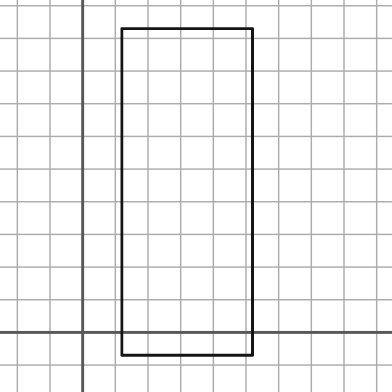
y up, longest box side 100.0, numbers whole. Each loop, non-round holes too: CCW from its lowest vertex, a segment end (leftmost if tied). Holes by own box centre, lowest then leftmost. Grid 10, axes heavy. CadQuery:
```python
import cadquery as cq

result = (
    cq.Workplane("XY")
    .moveTo(12.0, -7.0)
    .lineTo(52.0, -7.0)
    .lineTo(52.0, 93.0)
    .lineTo(12.0, 93.0)
    .close()
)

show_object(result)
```